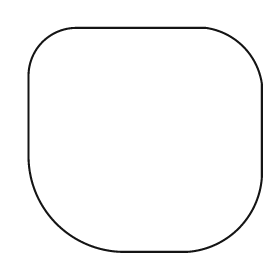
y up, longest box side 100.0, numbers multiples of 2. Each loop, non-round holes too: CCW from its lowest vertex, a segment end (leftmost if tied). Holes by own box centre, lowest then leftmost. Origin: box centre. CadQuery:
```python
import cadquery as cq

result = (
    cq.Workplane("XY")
    .moveTo(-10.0, -48.0)
    .lineTo(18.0, -48.0)
    .threePointArc((40.0, -38.0), (50.0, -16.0))
    .lineTo(50.0, 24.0)
    .threePointArc((42.0, 40.0), (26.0, 48.0))
    .lineTo(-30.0, 48.0)
    .threePointArc((-44.0, 42.0), (-50.0, 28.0))
    .lineTo(-50.0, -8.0)
    .threePointArc((-38.0, -36.0), (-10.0, -48.0))
    .close()
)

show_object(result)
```